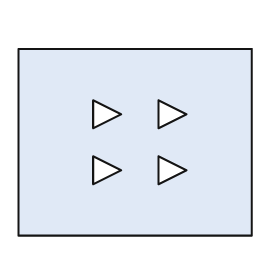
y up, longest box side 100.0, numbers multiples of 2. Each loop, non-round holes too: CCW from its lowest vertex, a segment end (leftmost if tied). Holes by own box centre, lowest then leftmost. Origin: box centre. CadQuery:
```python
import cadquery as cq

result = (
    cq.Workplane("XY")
    .moveTo(-50.0, -40.0)
    .lineTo(50.0, -40.0)
    .lineTo(50.0, 40.0)
    .lineTo(-50.0, 40.0)
    .close()
    .moveTo(-18.0, -18.0)
    .lineTo(-6.0, -12.0)
    .lineTo(-18.0, -6.0)
    .close()
    .moveTo(10.0, -18.0)
    .lineTo(22.0, -12.0)
    .lineTo(10.0, -6.0)
    .close()
    .moveTo(-18.0, 6.0)
    .lineTo(-6.0, 12.0)
    .lineTo(-18.0, 18.0)
    .close()
    .moveTo(10.0, 6.0)
    .lineTo(22.0, 12.0)
    .lineTo(10.0, 18.0)
    .close()
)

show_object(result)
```